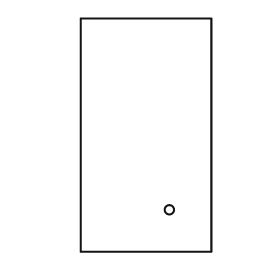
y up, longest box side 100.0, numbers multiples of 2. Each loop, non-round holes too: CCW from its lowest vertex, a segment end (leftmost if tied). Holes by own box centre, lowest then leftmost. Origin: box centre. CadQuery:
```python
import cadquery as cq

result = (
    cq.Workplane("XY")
    .moveTo(-28.0, -50.0)
    .lineTo(28.0, -50.0)
    .lineTo(28.0, 50.0)
    .lineTo(-28.0, 50.0)
    .close()
    .moveTo(10.0, -32.0)
    .circle(2.0)
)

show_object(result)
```